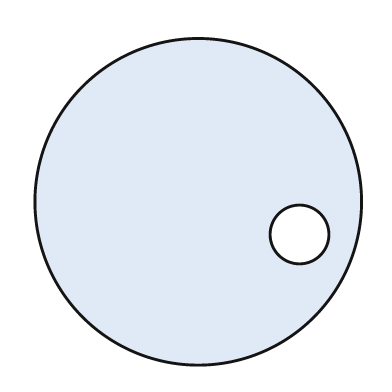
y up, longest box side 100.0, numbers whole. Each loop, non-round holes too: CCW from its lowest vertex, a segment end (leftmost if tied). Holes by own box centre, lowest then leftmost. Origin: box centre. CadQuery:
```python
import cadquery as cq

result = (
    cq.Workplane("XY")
    .moveTo(0.0, 0.0)
    .circle(50.0)
    .moveTo(31.0, -10.0)
    .circle(9.0)
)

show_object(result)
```